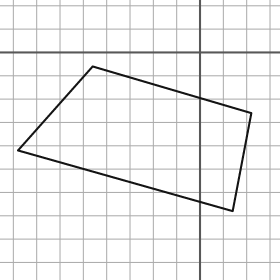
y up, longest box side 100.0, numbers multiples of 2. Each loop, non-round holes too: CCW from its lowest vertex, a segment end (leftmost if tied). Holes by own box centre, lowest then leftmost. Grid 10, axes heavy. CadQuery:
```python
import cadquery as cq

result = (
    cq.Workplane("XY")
    .moveTo(14.0, -68.0)
    .lineTo(22.0, -26.0)
    .lineTo(-46.0, -6.0)
    .lineTo(-78.0, -42.0)
    .close()
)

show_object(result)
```